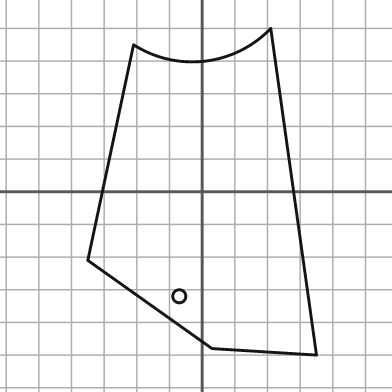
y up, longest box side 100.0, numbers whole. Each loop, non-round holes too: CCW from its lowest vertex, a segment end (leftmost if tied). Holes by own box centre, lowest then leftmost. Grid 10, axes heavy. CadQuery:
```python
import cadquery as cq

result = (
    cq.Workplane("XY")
    .moveTo(35.0, -50.0)
    .lineTo(21.0, 50.0)
    .threePointArc((1.0, 40.0), (-21.0, 45.0))
    .lineTo(-35.0, -21.0)
    .lineTo(3.0, -48.0)
    .close()
    .moveTo(-7.0, -32.0)
    .circle(2.0)
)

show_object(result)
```